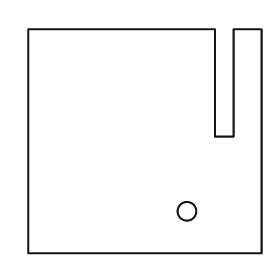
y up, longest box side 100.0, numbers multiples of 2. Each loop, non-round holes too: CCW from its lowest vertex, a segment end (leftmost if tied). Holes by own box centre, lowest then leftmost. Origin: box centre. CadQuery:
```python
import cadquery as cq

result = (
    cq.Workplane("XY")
    .moveTo(-50.0, -48.0)
    .lineTo(50.0, -48.0)
    .lineTo(50.0, 48.0)
    .lineTo(38.0, 48.0)
    .lineTo(38.0, 2.0)
    .lineTo(30.0, 2.0)
    .lineTo(30.0, 48.0)
    .lineTo(-50.0, 48.0)
    .close()
    .moveTo(18.0, -30.0)
    .circle(4.0)
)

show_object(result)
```